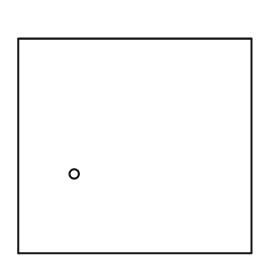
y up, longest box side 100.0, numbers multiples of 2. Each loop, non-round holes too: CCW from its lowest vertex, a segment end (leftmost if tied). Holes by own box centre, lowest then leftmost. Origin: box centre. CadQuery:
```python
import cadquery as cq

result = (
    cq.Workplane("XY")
    .moveTo(-50.0, -46.0)
    .lineTo(50.0, -46.0)
    .lineTo(50.0, 46.0)
    .lineTo(-50.0, 46.0)
    .close()
    .moveTo(-26.0, -12.0)
    .circle(2.0)
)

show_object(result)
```